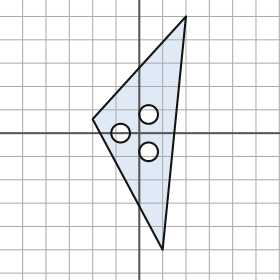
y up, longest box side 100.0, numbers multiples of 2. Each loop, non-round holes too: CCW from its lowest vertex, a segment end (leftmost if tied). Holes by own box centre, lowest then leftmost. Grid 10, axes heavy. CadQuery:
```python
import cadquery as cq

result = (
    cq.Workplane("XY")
    .moveTo(10.0, -50.0)
    .lineTo(20.0, 50.0)
    .lineTo(-20.0, 6.0)
    .close()
    .moveTo(4.0, -8.0)
    .circle(4.0)
    .moveTo(-8.0, 0.0)
    .circle(4.0)
    .moveTo(4.0, 8.0)
    .circle(4.0)
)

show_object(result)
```